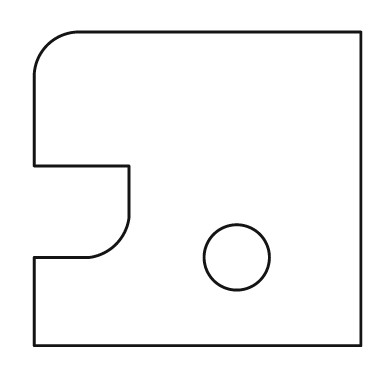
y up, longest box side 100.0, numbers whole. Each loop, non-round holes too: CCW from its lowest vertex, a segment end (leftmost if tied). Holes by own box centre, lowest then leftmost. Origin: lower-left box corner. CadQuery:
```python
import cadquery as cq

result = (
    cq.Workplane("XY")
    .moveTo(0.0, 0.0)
    .lineTo(100.0, 0.0)
    .lineTo(100.0, 96.0)
    .lineTo(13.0, 96.0)
    .threePointArc((4.0, 92.0), (0.0, 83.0))
    .lineTo(0.0, 55.0)
    .lineTo(29.0, 55.0)
    .lineTo(29.0, 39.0)
    .threePointArc((25.0, 31.0), (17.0, 27.0))
    .lineTo(0.0, 27.0)
    .close()
    .moveTo(62.0, 27.0)
    .circle(10.0)
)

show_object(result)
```